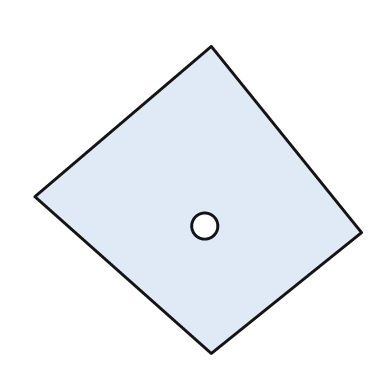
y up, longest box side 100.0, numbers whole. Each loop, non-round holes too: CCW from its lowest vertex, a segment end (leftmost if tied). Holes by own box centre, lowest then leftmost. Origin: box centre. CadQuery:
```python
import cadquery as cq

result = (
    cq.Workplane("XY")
    .moveTo(4.0, -47.0)
    .lineTo(50.0, -10.0)
    .lineTo(4.0, 47.0)
    .lineTo(-50.0, 1.0)
    .close()
    .moveTo(2.0, -8.0)
    .circle(4.0)
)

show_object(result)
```